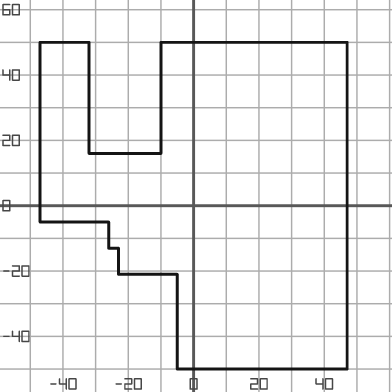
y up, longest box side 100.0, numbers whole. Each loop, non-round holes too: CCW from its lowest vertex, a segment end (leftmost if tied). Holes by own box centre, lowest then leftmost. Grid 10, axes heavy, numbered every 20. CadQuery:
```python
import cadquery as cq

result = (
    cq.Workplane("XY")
    .moveTo(-5.0, -50.0)
    .lineTo(47.0, -50.0)
    .lineTo(47.0, 50.0)
    .lineTo(-10.0, 50.0)
    .lineTo(-10.0, 16.0)
    .lineTo(-32.0, 16.0)
    .lineTo(-32.0, 50.0)
    .lineTo(-47.0, 50.0)
    .lineTo(-47.0, -5.0)
    .lineTo(-26.0, -5.0)
    .lineTo(-26.0, -13.0)
    .lineTo(-23.0, -13.0)
    .lineTo(-23.0, -21.0)
    .lineTo(-5.0, -21.0)
    .close()
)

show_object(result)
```